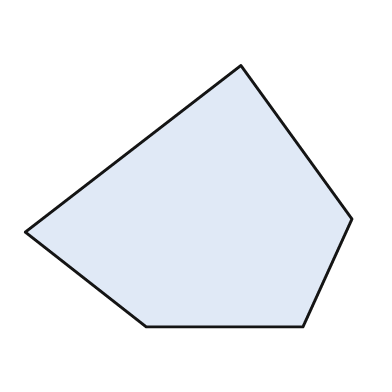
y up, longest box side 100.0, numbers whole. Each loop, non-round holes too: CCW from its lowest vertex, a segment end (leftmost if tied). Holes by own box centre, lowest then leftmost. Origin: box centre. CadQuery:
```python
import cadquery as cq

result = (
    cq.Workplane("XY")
    .moveTo(-13.0, -40.0)
    .lineTo(35.0, -40.0)
    .lineTo(50.0, -7.0)
    .lineTo(16.0, 40.0)
    .lineTo(-50.0, -11.0)
    .close()
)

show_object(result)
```